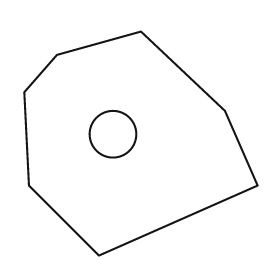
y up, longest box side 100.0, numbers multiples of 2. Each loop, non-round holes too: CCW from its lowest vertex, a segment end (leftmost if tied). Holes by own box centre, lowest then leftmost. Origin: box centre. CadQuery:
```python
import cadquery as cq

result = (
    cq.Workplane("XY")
    .moveTo(-18.0, -48.0)
    .lineTo(50.0, -18.0)
    .lineTo(36.0, 14.0)
    .lineTo(0.0, 48.0)
    .lineTo(-36.0, 38.0)
    .lineTo(-50.0, 22.0)
    .lineTo(-48.0, -18.0)
    .close()
    .moveTo(-12.0, 4.0)
    .circle(10.0)
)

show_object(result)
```